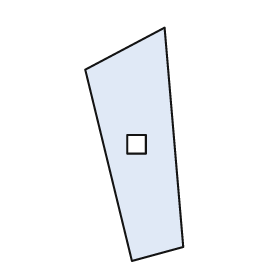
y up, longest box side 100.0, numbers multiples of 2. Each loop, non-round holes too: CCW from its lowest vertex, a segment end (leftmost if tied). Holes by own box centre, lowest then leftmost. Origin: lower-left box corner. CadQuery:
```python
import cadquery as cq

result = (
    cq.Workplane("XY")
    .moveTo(20.0, 0.0)
    .lineTo(42.0, 6.0)
    .lineTo(34.0, 100.0)
    .lineTo(0.0, 82.0)
    .close()
    .moveTo(18.0, 46.0)
    .lineTo(26.0, 46.0)
    .lineTo(26.0, 54.0)
    .lineTo(18.0, 54.0)
    .close()
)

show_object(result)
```